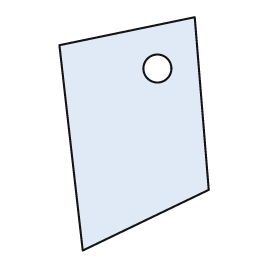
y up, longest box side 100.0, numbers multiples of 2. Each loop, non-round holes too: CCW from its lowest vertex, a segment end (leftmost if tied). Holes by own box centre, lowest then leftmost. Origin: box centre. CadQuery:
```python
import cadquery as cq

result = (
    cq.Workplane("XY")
    .moveTo(-22.0, -50.0)
    .lineTo(32.0, -24.0)
    .lineTo(26.0, 50.0)
    .lineTo(-32.0, 38.0)
    .close()
    .moveTo(10.0, 28.0)
    .circle(6.0)
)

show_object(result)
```